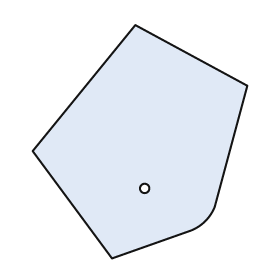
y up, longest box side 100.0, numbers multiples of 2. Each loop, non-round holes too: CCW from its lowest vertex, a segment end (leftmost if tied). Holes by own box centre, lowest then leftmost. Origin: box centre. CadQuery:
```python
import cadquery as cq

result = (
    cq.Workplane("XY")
    .moveTo(-12.0, -50.0)
    .lineTo(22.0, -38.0)
    .threePointArc((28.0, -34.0), (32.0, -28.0))
    .lineTo(46.0, 24.0)
    .lineTo(-2.0, 50.0)
    .lineTo(-46.0, -4.0)
    .close()
    .moveTo(2.0, -20.0)
    .circle(2.0)
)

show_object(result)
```